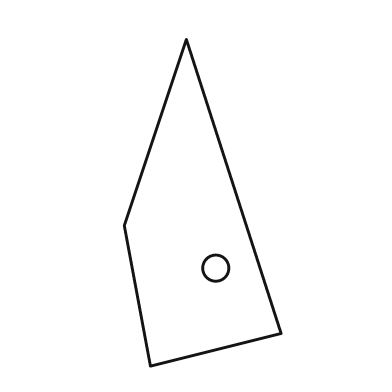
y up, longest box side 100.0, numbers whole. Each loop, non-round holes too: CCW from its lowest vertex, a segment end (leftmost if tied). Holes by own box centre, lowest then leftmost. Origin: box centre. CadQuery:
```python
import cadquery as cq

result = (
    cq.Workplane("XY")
    .moveTo(-16.0, -50.0)
    .lineTo(24.0, -40.0)
    .lineTo(-5.0, 50.0)
    .lineTo(-24.0, -7.0)
    .close()
    .moveTo(4.0, -20.0)
    .circle(4.0)
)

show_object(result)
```